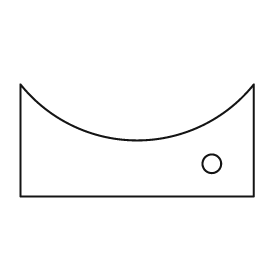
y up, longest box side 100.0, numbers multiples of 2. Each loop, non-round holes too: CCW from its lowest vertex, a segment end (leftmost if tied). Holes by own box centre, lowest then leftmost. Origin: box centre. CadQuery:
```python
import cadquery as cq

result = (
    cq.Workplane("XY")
    .moveTo(-50.0, -24.0)
    .lineTo(50.0, -24.0)
    .lineTo(50.0, 24.0)
    .threePointArc((0.0, 0.0), (-50.0, 24.0))
    .close()
    .moveTo(32.0, -10.0)
    .circle(4.0)
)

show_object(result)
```